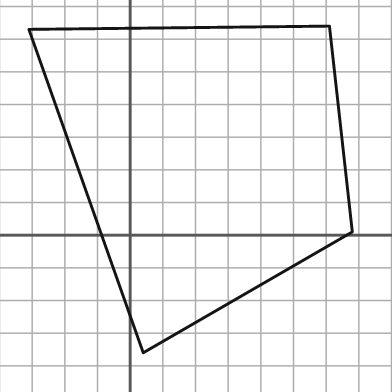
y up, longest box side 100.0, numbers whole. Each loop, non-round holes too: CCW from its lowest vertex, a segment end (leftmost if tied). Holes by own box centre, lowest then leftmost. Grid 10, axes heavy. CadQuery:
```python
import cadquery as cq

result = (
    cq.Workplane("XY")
    .moveTo(4.0, -36.0)
    .lineTo(68.0, 1.0)
    .lineTo(61.0, 64.0)
    .lineTo(-31.0, 63.0)
    .close()
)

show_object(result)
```